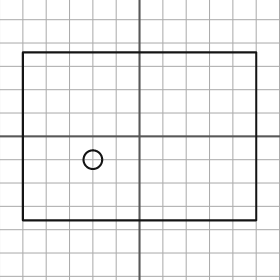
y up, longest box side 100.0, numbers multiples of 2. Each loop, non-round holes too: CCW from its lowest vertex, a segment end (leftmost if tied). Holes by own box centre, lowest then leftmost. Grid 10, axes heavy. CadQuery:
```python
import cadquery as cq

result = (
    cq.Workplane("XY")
    .moveTo(-50.0, -36.0)
    .lineTo(50.0, -36.0)
    .lineTo(50.0, 36.0)
    .lineTo(-50.0, 36.0)
    .close()
    .moveTo(-20.0, -10.0)
    .circle(4.0)
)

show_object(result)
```